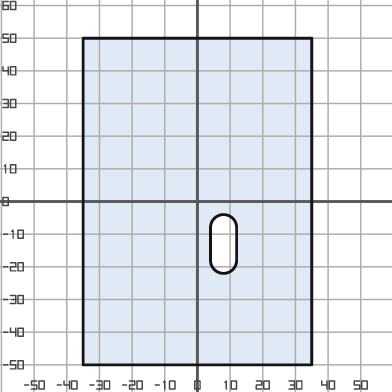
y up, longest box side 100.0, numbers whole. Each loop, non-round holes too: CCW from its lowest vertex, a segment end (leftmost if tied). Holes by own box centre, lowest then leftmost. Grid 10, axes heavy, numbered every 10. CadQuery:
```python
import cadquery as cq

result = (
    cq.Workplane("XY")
    .moveTo(-35.0, -50.0)
    .lineTo(35.0, -50.0)
    .lineTo(35.0, 50.0)
    .lineTo(-35.0, 50.0)
    .close()
    .moveTo(4.0, -18.0)
    .threePointArc((8.0, -22.0), (12.0, -18.0))
    .lineTo(12.0, -8.0)
    .threePointArc((8.0, -4.0), (4.0, -8.0))
    .close()
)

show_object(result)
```